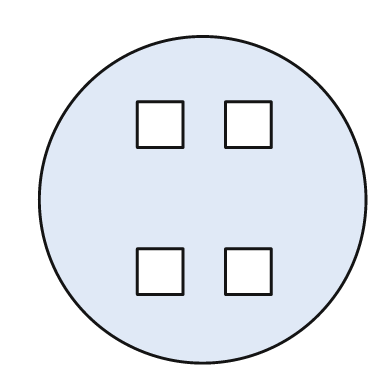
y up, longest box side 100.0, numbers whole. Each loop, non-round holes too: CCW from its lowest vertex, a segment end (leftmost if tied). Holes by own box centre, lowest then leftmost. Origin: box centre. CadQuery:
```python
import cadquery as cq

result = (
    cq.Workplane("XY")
    .moveTo(0.0, 0.0)
    .circle(50.0)
    .moveTo(-20.0, -29.0)
    .lineTo(-6.0, -29.0)
    .lineTo(-6.0, -15.0)
    .lineTo(-20.0, -15.0)
    .close()
    .moveTo(7.0, -29.0)
    .lineTo(21.0, -29.0)
    .lineTo(21.0, -15.0)
    .lineTo(7.0, -15.0)
    .close()
    .moveTo(-20.0, 16.0)
    .lineTo(-6.0, 16.0)
    .lineTo(-6.0, 30.0)
    .lineTo(-20.0, 30.0)
    .close()
    .moveTo(7.0, 16.0)
    .lineTo(21.0, 16.0)
    .lineTo(21.0, 30.0)
    .lineTo(7.0, 30.0)
    .close()
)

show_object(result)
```